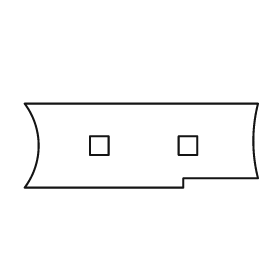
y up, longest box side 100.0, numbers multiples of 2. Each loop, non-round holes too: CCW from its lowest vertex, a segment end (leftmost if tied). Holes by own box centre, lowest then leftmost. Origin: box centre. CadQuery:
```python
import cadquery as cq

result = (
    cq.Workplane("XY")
    .moveTo(-50.0, -18.0)
    .lineTo(18.0, -18.0)
    .lineTo(18.0, -14.0)
    .lineTo(50.0, -14.0)
    .threePointArc((48.0, 2.0), (50.0, 18.0))
    .lineTo(-50.0, 18.0)
    .threePointArc((-44.0, 0.0), (-50.0, -18.0))
    .close()
    .moveTo(-22.0, -4.0)
    .lineTo(-14.0, -4.0)
    .lineTo(-14.0, 4.0)
    .lineTo(-22.0, 4.0)
    .close()
    .moveTo(16.0, -4.0)
    .lineTo(24.0, -4.0)
    .lineTo(24.0, 4.0)
    .lineTo(16.0, 4.0)
    .close()
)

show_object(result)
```